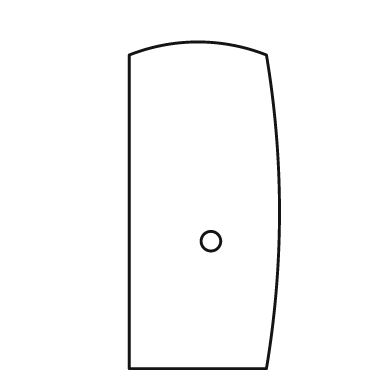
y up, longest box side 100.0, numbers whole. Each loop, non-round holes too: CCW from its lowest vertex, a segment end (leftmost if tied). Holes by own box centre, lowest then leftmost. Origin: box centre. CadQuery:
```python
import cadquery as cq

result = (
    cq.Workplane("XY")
    .moveTo(-23.0, -50.0)
    .lineTo(19.0, -50.0)
    .threePointArc((23.0, -2.0), (19.0, 46.0))
    .threePointArc((-2.0, 50.0), (-23.0, 46.0))
    .close()
    .moveTo(2.0, -11.0)
    .circle(3.0)
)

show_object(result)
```